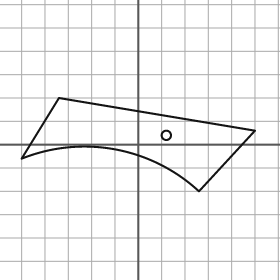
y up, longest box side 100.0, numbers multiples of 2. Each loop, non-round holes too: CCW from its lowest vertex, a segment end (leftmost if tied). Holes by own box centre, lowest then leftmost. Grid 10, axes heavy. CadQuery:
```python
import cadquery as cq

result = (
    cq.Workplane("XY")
    .moveTo(26.0, -20.0)
    .lineTo(50.0, 6.0)
    .lineTo(-34.0, 20.0)
    .lineTo(-50.0, -6.0)
    .threePointArc((-10.0, -2.0), (26.0, -20.0))
    .close()
    .moveTo(12.0, 4.0)
    .circle(2.0)
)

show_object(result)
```